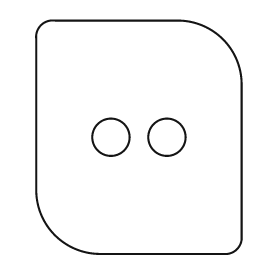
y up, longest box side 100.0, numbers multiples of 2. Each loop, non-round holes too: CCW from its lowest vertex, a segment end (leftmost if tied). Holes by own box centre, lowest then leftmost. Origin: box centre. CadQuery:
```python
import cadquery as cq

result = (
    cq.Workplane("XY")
    .moveTo(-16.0, -50.0)
    .lineTo(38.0, -50.0)
    .threePointArc((42.0, -48.0), (44.0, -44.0))
    .lineTo(44.0, 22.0)
    .threePointArc((36.0, 42.0), (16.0, 50.0))
    .lineTo(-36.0, 50.0)
    .threePointArc((-42.0, 48.0), (-44.0, 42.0))
    .lineTo(-44.0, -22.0)
    .threePointArc((-36.0, -42.0), (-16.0, -50.0))
    .close()
    .moveTo(-12.0, 0.0)
    .circle(8.0)
    .moveTo(12.0, 0.0)
    .circle(8.0)
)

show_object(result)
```